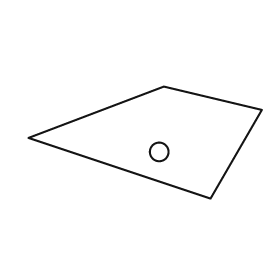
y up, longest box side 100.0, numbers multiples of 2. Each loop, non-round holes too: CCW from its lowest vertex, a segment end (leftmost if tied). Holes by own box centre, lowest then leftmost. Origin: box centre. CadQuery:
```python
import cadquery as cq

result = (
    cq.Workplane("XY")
    .moveTo(28.0, -24.0)
    .lineTo(50.0, 14.0)
    .lineTo(8.0, 24.0)
    .lineTo(-50.0, 2.0)
    .close()
    .moveTo(6.0, -4.0)
    .circle(4.0)
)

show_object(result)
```